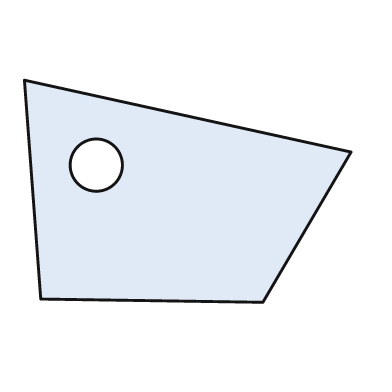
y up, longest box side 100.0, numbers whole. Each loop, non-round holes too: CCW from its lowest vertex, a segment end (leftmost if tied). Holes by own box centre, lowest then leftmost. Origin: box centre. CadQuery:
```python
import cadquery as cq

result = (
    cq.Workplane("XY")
    .moveTo(23.0, -34.0)
    .lineTo(50.0, 12.0)
    .lineTo(-50.0, 34.0)
    .lineTo(-45.0, -33.0)
    .close()
    .moveTo(-28.0, 8.0)
    .circle(8.0)
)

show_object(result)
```